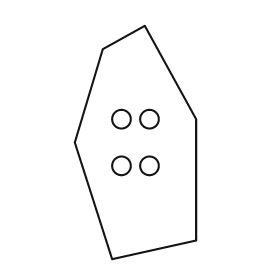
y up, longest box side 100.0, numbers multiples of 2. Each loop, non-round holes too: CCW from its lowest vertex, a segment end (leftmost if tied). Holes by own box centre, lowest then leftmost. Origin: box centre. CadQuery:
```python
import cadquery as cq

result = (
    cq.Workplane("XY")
    .moveTo(-10.0, -50.0)
    .lineTo(26.0, -42.0)
    .lineTo(26.0, 10.0)
    .lineTo(4.0, 50.0)
    .lineTo(-14.0, 40.0)
    .lineTo(-26.0, 0.0)
    .close()
    .moveTo(-6.0, -10.0)
    .circle(4.0)
    .moveTo(6.0, -10.0)
    .circle(4.0)
    .moveTo(-6.0, 10.0)
    .circle(4.0)
    .moveTo(6.0, 10.0)
    .circle(4.0)
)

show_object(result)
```